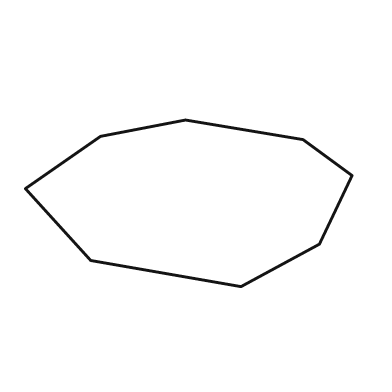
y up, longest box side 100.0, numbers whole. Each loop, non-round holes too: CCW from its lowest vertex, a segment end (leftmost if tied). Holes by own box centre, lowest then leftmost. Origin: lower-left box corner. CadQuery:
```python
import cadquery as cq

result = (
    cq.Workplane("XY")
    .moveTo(66.0, 0.0)
    .lineTo(90.0, 13.0)
    .lineTo(100.0, 34.0)
    .lineTo(85.0, 45.0)
    .lineTo(49.0, 51.0)
    .lineTo(23.0, 46.0)
    .lineTo(0.0, 30.0)
    .lineTo(20.0, 8.0)
    .close()
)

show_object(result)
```